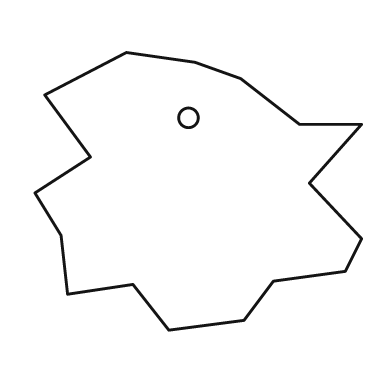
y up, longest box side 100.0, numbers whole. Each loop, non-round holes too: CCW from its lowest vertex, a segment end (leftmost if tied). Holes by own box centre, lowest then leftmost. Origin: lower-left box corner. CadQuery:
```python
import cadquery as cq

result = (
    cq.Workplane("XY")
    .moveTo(41.0, 0.0)
    .lineTo(64.0, 3.0)
    .lineTo(73.0, 15.0)
    .lineTo(95.0, 18.0)
    .lineTo(100.0, 28.0)
    .lineTo(84.0, 45.0)
    .lineTo(100.0, 63.0)
    .lineTo(81.0, 63.0)
    .lineTo(63.0, 77.0)
    .lineTo(49.0, 82.0)
    .lineTo(28.0, 85.0)
    .lineTo(3.0, 72.0)
    .lineTo(17.0, 53.0)
    .lineTo(0.0, 42.0)
    .lineTo(8.0, 29.0)
    .lineTo(10.0, 11.0)
    .lineTo(30.0, 14.0)
    .close()
    .moveTo(47.0, 65.0)
    .circle(3.0)
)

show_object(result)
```